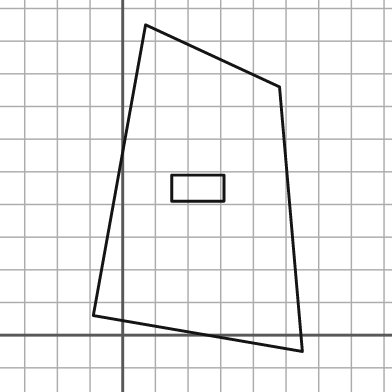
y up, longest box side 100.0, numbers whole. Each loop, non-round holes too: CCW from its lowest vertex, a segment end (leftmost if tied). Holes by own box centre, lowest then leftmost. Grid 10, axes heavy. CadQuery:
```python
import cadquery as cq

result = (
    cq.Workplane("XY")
    .moveTo(55.0, -5.0)
    .lineTo(48.0, 76.0)
    .lineTo(7.0, 95.0)
    .lineTo(-9.0, 6.0)
    .close()
    .moveTo(15.0, 41.0)
    .lineTo(31.0, 41.0)
    .lineTo(31.0, 49.0)
    .lineTo(15.0, 49.0)
    .close()
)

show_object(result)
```